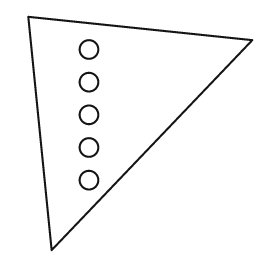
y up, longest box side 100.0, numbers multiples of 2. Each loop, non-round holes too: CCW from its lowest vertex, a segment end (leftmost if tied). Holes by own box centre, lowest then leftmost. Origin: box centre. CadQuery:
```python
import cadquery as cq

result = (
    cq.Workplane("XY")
    .moveTo(-38.0, -50.0)
    .lineTo(48.0, 40.0)
    .lineTo(-48.0, 50.0)
    .close()
    .moveTo(-22.0, -20.0)
    .circle(4.0)
    .moveTo(-22.0, -6.0)
    .circle(4.0)
    .moveTo(-22.0, 8.0)
    .circle(4.0)
    .moveTo(-22.0, 22.0)
    .circle(4.0)
    .moveTo(-22.0, 36.0)
    .circle(4.0)
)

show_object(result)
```